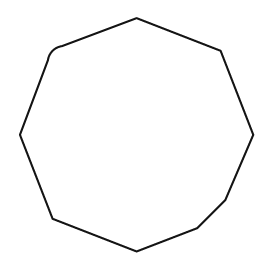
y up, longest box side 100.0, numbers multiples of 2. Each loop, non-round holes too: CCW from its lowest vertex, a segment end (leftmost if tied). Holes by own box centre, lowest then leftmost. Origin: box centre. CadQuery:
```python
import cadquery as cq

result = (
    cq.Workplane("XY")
    .moveTo(0.0, -50.0)
    .lineTo(26.0, -40.0)
    .lineTo(38.0, -28.0)
    .lineTo(50.0, 0.0)
    .lineTo(36.0, 36.0)
    .lineTo(0.0, 50.0)
    .lineTo(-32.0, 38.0)
    .threePointArc((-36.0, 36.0), (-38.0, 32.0))
    .lineTo(-50.0, 0.0)
    .lineTo(-36.0, -36.0)
    .close()
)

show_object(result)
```